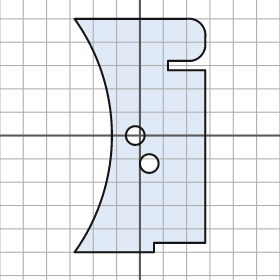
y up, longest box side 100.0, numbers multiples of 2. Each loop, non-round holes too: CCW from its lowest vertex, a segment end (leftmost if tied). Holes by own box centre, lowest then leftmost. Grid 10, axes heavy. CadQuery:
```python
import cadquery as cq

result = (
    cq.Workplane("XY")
    .moveTo(-28.0, -50.0)
    .lineTo(6.0, -50.0)
    .lineTo(6.0, -46.0)
    .lineTo(28.0, -46.0)
    .lineTo(28.0, 28.0)
    .lineTo(12.0, 28.0)
    .lineTo(12.0, 32.0)
    .lineTo(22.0, 32.0)
    .threePointArc((26.0, 34.0), (28.0, 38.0))
    .lineTo(28.0, 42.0)
    .threePointArc((26.0, 48.0), (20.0, 50.0))
    .lineTo(-28.0, 50.0)
    .threePointArc((-12.0, 0.0), (-28.0, -50.0))
    .close()
    .moveTo(4.0, -12.0)
    .circle(4.0)
    .moveTo(-2.0, 0.0)
    .circle(4.0)
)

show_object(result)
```